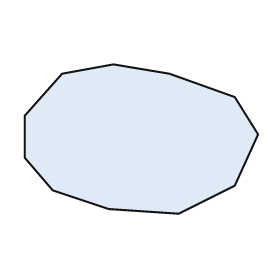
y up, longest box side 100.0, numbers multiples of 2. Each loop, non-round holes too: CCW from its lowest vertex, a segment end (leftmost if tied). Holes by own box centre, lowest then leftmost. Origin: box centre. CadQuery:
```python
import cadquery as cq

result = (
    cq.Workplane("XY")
    .moveTo(16.0, -32.0)
    .lineTo(40.0, -20.0)
    .lineTo(50.0, 2.0)
    .lineTo(40.0, 18.0)
    .lineTo(12.0, 28.0)
    .lineTo(-12.0, 32.0)
    .lineTo(-34.0, 28.0)
    .lineTo(-50.0, 10.0)
    .lineTo(-50.0, -8.0)
    .lineTo(-38.0, -22.0)
    .lineTo(-14.0, -30.0)
    .close()
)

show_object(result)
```